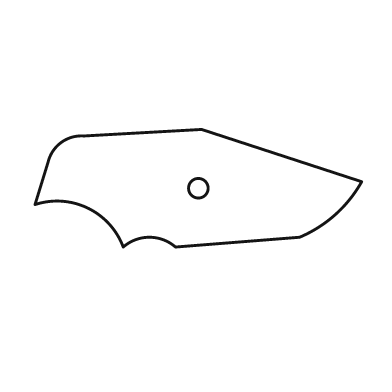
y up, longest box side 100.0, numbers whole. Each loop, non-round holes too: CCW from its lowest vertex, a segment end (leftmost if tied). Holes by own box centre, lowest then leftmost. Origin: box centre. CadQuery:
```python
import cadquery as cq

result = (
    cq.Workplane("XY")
    .moveTo(-23.0, -18.0)
    .threePointArc((-15.0, -15.0), (-7.0, -18.0))
    .lineTo(31.0, -15.0)
    .threePointArc((42.0, -8.0), (50.0, 2.0))
    .lineTo(1.0, 18.0)
    .lineTo(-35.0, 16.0)
    .threePointArc((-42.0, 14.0), (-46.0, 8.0))
    .lineTo(-50.0, -5.0)
    .threePointArc((-34.0, -6.0), (-23.0, -18.0))
    .close()
    .moveTo(0.0, 0.0)
    .circle(3.0)
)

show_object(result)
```